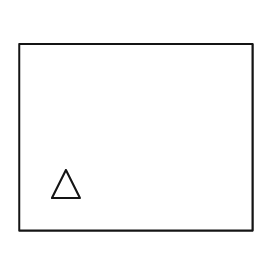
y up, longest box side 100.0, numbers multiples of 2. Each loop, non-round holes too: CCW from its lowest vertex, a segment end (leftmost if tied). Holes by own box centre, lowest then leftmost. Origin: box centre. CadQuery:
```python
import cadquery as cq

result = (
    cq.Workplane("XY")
    .moveTo(-50.0, -40.0)
    .lineTo(50.0, -40.0)
    .lineTo(50.0, 40.0)
    .lineTo(-50.0, 40.0)
    .close()
    .moveTo(-36.0, -26.0)
    .lineTo(-24.0, -26.0)
    .lineTo(-30.0, -14.0)
    .close()
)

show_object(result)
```